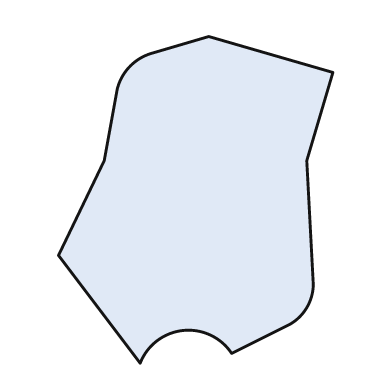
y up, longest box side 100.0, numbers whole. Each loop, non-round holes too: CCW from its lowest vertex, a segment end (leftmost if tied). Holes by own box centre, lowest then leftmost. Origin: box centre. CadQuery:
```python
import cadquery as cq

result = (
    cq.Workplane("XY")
    .moveTo(-17.0, -50.0)
    .threePointArc((-4.0, -40.0), (11.0, -47.0))
    .lineTo(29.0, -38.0)
    .threePointArc((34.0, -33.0), (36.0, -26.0))
    .lineTo(34.0, 12.0)
    .lineTo(42.0, 39.0)
    .lineTo(4.0, 50.0)
    .lineTo(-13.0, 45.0)
    .threePointArc((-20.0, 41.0), (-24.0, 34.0))
    .lineTo(-28.0, 12.0)
    .lineTo(-42.0, -17.0)
    .close()
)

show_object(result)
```